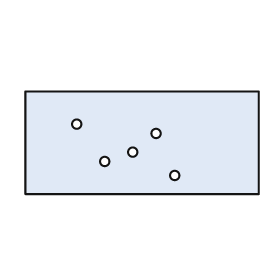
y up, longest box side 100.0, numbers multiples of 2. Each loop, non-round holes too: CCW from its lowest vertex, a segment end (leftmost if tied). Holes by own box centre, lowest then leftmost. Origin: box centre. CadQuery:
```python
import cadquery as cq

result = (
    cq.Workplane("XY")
    .moveTo(-50.0, -22.0)
    .lineTo(50.0, -22.0)
    .lineTo(50.0, 22.0)
    .lineTo(-50.0, 22.0)
    .close()
    .moveTo(14.0, -14.0)
    .circle(2.0)
    .moveTo(-16.0, -8.0)
    .circle(2.0)
    .moveTo(-4.0, -4.0)
    .circle(2.0)
    .moveTo(6.0, 4.0)
    .circle(2.0)
    .moveTo(-28.0, 8.0)
    .circle(2.0)
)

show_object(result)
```